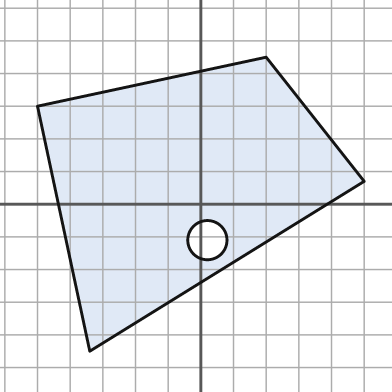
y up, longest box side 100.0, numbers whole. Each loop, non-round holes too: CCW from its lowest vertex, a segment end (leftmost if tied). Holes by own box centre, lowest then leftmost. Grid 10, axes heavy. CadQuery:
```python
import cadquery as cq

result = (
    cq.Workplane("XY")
    .moveTo(-34.0, -45.0)
    .lineTo(50.0, 7.0)
    .lineTo(20.0, 45.0)
    .lineTo(-50.0, 30.0)
    .close()
    .moveTo(2.0, -11.0)
    .circle(6.0)
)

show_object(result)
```